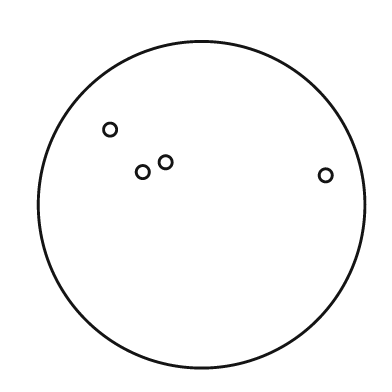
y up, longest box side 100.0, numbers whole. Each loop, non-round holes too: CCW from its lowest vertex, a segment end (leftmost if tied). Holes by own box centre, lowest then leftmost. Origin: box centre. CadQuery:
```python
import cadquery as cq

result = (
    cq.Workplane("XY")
    .moveTo(0.0, 0.0)
    .circle(50.0)
    .moveTo(38.0, 9.0)
    .circle(2.0)
    .moveTo(-18.0, 10.0)
    .circle(2.0)
    .moveTo(-11.0, 13.0)
    .circle(2.0)
    .moveTo(-28.0, 23.0)
    .circle(2.0)
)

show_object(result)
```